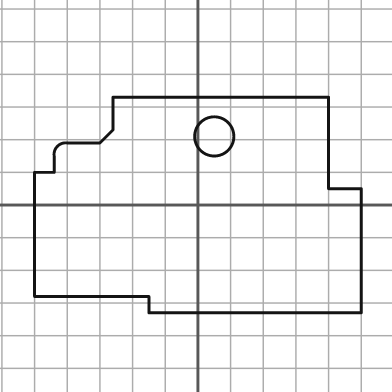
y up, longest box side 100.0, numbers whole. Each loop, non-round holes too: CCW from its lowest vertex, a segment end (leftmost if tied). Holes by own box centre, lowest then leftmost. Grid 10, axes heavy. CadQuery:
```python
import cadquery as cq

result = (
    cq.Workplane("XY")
    .moveTo(-15.0, -33.0)
    .lineTo(50.0, -33.0)
    .lineTo(50.0, 5.0)
    .lineTo(40.0, 5.0)
    .lineTo(40.0, 33.0)
    .lineTo(-26.0, 33.0)
    .lineTo(-26.0, 23.0)
    .lineTo(-30.0, 19.0)
    .lineTo(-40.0, 19.0)
    .threePointArc((-43.0, 18.0), (-44.0, 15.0))
    .lineTo(-44.0, 10.0)
    .lineTo(-50.0, 10.0)
    .lineTo(-50.0, -28.0)
    .lineTo(-15.0, -28.0)
    .close()
    .moveTo(5.0, 21.0)
    .circle(6.0)
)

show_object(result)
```